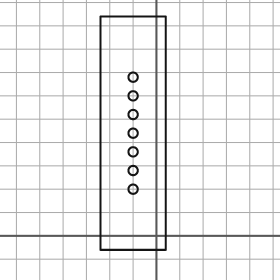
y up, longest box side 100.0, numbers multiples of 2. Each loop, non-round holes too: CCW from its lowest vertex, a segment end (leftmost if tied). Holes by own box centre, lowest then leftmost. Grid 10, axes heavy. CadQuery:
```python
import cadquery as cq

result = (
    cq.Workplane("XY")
    .moveTo(-24.0, -6.0)
    .lineTo(4.0, -6.0)
    .lineTo(4.0, 94.0)
    .lineTo(-24.0, 94.0)
    .close()
    .moveTo(-10.0, 20.0)
    .circle(2.0)
    .moveTo(-10.0, 28.0)
    .circle(2.0)
    .moveTo(-10.0, 36.0)
    .circle(2.0)
    .moveTo(-10.0, 44.0)
    .circle(2.0)
    .moveTo(-10.0, 52.0)
    .circle(2.0)
    .moveTo(-10.0, 60.0)
    .circle(2.0)
    .moveTo(-10.0, 68.0)
    .circle(2.0)
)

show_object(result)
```